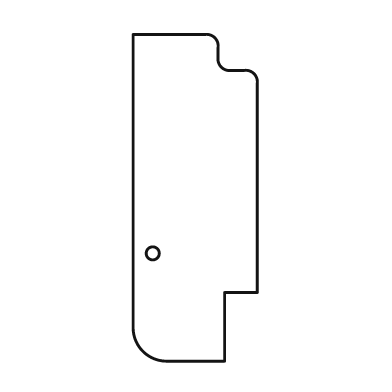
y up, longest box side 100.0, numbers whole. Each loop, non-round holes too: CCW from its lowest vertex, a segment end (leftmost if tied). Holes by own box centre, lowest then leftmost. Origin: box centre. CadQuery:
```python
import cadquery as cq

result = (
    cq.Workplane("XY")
    .moveTo(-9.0, -50.0)
    .lineTo(9.0, -50.0)
    .lineTo(9.0, -29.0)
    .lineTo(19.0, -29.0)
    .lineTo(19.0, 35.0)
    .threePointArc((18.0, 38.0), (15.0, 39.0))
    .lineTo(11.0, 39.0)
    .threePointArc((8.0, 40.0), (7.0, 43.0))
    .lineTo(7.0, 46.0)
    .threePointArc((6.0, 49.0), (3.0, 50.0))
    .lineTo(-19.0, 50.0)
    .lineTo(-19.0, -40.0)
    .threePointArc((-16.0, -47.0), (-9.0, -50.0))
    .close()
    .moveTo(-13.0, -17.0)
    .circle(2.0)
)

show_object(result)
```